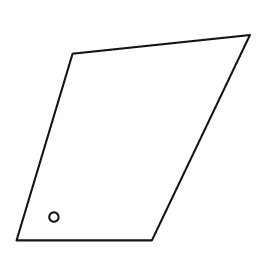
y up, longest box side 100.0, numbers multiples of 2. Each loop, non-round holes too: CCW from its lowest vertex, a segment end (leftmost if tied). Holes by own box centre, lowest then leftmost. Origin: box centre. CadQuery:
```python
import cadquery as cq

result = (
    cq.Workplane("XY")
    .moveTo(-50.0, -44.0)
    .lineTo(8.0, -44.0)
    .lineTo(50.0, 44.0)
    .lineTo(-26.0, 36.0)
    .close()
    .moveTo(-34.0, -34.0)
    .circle(2.0)
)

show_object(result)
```